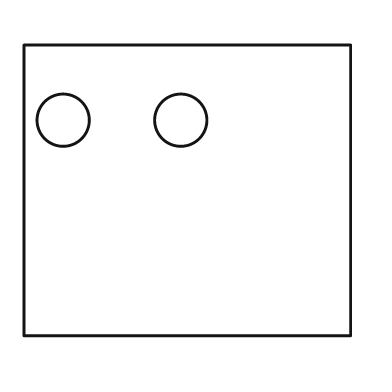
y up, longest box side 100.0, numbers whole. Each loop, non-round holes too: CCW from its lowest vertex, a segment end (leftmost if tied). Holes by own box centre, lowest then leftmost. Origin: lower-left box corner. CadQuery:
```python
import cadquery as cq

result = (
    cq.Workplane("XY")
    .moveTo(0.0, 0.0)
    .lineTo(100.0, 0.0)
    .lineTo(100.0, 89.0)
    .lineTo(0.0, 89.0)
    .close()
    .moveTo(12.0, 66.0)
    .circle(8.0)
    .moveTo(48.0, 66.0)
    .circle(8.0)
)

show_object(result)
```